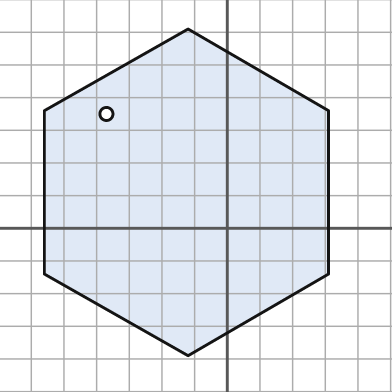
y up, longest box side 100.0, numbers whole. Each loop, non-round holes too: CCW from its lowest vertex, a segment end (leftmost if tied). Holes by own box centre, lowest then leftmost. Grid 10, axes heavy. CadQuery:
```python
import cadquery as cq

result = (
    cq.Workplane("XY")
    .moveTo(-12.0, -39.0)
    .lineTo(31.0, -14.0)
    .lineTo(31.0, 36.0)
    .lineTo(-12.0, 61.0)
    .lineTo(-56.0, 36.0)
    .lineTo(-56.0, -14.0)
    .close()
    .moveTo(-37.0, 35.0)
    .circle(2.0)
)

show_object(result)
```